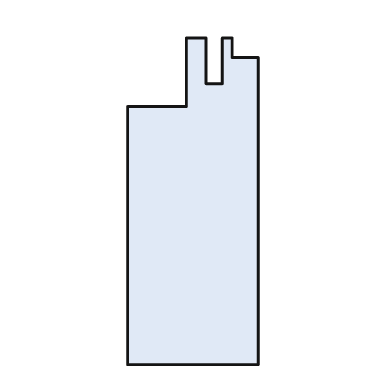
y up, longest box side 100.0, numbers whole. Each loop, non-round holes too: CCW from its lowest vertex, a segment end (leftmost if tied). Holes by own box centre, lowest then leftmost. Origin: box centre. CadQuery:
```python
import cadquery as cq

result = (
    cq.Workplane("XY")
    .moveTo(-20.0, -50.0)
    .lineTo(20.0, -50.0)
    .lineTo(20.0, 44.0)
    .lineTo(12.0, 44.0)
    .lineTo(12.0, 50.0)
    .lineTo(9.0, 50.0)
    .lineTo(9.0, 36.0)
    .lineTo(4.0, 36.0)
    .lineTo(4.0, 50.0)
    .lineTo(-2.0, 50.0)
    .lineTo(-2.0, 29.0)
    .lineTo(-20.0, 29.0)
    .close()
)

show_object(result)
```